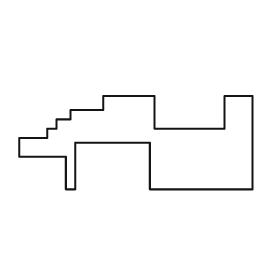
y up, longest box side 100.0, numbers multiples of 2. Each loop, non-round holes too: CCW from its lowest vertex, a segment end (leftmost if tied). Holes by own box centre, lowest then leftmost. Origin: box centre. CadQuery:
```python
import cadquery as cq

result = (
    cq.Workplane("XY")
    .moveTo(-30.0, -20.0)
    .lineTo(-26.0, -20.0)
    .lineTo(-26.0, 0.0)
    .lineTo(6.0, 0.0)
    .lineTo(6.0, -20.0)
    .lineTo(50.0, -20.0)
    .lineTo(50.0, 20.0)
    .lineTo(38.0, 20.0)
    .lineTo(38.0, 6.0)
    .lineTo(8.0, 6.0)
    .lineTo(8.0, 20.0)
    .lineTo(-14.0, 20.0)
    .lineTo(-14.0, 14.0)
    .lineTo(-28.0, 14.0)
    .lineTo(-28.0, 10.0)
    .lineTo(-34.0, 10.0)
    .lineTo(-34.0, 6.0)
    .lineTo(-38.0, 6.0)
    .lineTo(-38.0, 2.0)
    .lineTo(-50.0, 2.0)
    .lineTo(-50.0, -6.0)
    .lineTo(-30.0, -6.0)
    .close()
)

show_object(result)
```